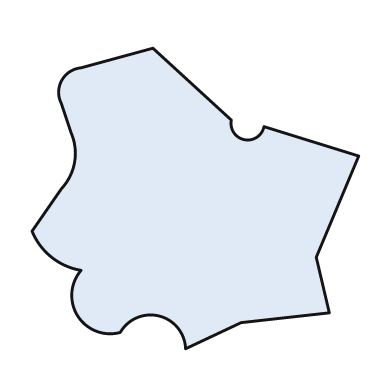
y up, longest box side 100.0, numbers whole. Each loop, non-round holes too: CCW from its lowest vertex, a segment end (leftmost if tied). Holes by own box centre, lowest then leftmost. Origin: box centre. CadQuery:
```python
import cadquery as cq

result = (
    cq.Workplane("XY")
    .moveTo(-3.0, -46.0)
    .lineTo(14.0, -38.0)
    .lineTo(41.0, -35.0)
    .lineTo(37.0, -18.0)
    .lineTo(50.0, 13.0)
    .lineTo(21.0, 22.0)
    .threePointArc((15.0, 18.0), (11.0, 24.0))
    .lineTo(-13.0, 46.0)
    .lineTo(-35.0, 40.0)
    .threePointArc((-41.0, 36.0), (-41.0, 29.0))
    .lineTo(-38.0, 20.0)
    .threePointArc((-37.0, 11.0), (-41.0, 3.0))
    .lineTo(-50.0, -10.0)
    .threePointArc((-44.0, -18.0), (-35.0, -22.0))
    .threePointArc((-36.0, -36.0), (-23.0, -41.0))
    .threePointArc((-11.0, -36.0), (-3.0, -46.0))
    .close()
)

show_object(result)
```